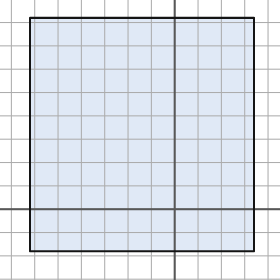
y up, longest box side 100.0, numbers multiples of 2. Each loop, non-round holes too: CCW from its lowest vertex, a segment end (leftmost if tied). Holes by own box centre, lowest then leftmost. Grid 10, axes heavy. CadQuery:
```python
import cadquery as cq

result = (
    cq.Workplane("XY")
    .moveTo(-62.0, -18.0)
    .lineTo(34.0, -18.0)
    .lineTo(34.0, 82.0)
    .lineTo(-62.0, 82.0)
    .close()
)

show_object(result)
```